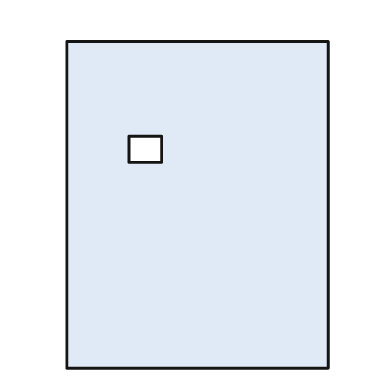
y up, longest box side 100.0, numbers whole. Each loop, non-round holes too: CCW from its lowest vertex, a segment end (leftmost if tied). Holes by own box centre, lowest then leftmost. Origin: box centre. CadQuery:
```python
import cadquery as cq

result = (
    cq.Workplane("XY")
    .moveTo(-40.0, -50.0)
    .lineTo(40.0, -50.0)
    .lineTo(40.0, 50.0)
    .lineTo(-40.0, 50.0)
    .close()
    .moveTo(-21.0, 13.0)
    .lineTo(-11.0, 13.0)
    .lineTo(-11.0, 21.0)
    .lineTo(-21.0, 21.0)
    .close()
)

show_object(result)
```